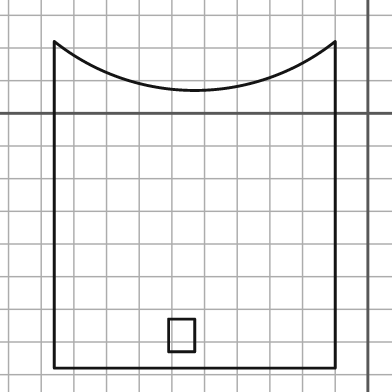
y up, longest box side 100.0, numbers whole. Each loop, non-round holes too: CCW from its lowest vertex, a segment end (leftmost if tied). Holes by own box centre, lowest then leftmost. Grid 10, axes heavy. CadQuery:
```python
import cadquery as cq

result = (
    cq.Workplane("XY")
    .moveTo(-96.0, -78.0)
    .lineTo(-10.0, -78.0)
    .lineTo(-10.0, 22.0)
    .threePointArc((-53.0, 7.0), (-96.0, 22.0))
    .close()
    .moveTo(-61.0, -73.0)
    .lineTo(-53.0, -73.0)
    .lineTo(-53.0, -63.0)
    .lineTo(-61.0, -63.0)
    .close()
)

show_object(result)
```